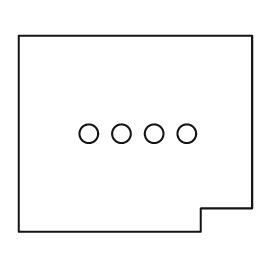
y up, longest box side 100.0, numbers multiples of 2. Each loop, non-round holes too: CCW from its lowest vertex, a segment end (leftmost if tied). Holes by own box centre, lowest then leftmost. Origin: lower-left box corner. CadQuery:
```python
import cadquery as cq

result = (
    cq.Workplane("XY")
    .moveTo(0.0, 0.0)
    .lineTo(78.0, 0.0)
    .lineTo(78.0, 10.0)
    .lineTo(100.0, 10.0)
    .lineTo(100.0, 84.0)
    .lineTo(0.0, 84.0)
    .close()
    .moveTo(30.0, 42.0)
    .circle(4.0)
    .moveTo(44.0, 42.0)
    .circle(4.0)
    .moveTo(58.0, 42.0)
    .circle(4.0)
    .moveTo(72.0, 42.0)
    .circle(4.0)
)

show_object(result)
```